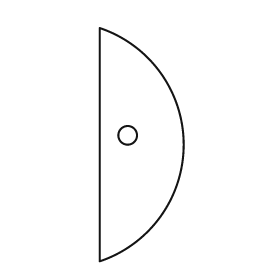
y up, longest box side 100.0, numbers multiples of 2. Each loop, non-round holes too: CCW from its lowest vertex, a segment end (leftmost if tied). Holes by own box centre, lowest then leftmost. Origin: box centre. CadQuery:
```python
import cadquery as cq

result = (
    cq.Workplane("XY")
    .moveTo(-18.0, -50.0)
    .threePointArc((18.0, 0.0), (-18.0, 50.0))
    .close()
    .moveTo(-6.0, 4.0)
    .circle(4.0)
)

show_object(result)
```